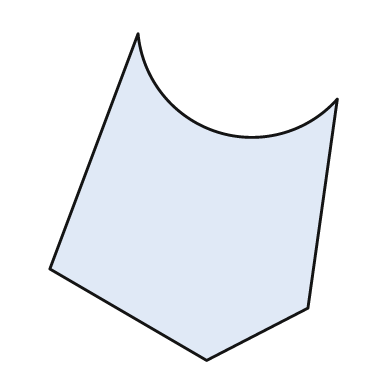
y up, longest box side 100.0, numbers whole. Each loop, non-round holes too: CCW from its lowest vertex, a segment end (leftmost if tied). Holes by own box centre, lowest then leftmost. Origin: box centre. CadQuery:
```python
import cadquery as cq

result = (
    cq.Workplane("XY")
    .moveTo(4.0, -50.0)
    .lineTo(35.0, -34.0)
    .lineTo(44.0, 30.0)
    .threePointArc((7.0, 20.0), (-17.0, 50.0))
    .lineTo(-44.0, -22.0)
    .close()
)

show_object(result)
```